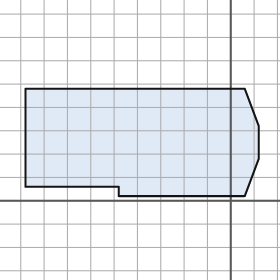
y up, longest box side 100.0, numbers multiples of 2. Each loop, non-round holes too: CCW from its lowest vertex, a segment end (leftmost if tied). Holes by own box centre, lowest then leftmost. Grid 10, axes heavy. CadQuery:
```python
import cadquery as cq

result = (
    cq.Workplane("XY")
    .moveTo(-48.0, 2.0)
    .lineTo(6.0, 2.0)
    .lineTo(12.0, 18.0)
    .lineTo(12.0, 32.0)
    .lineTo(6.0, 48.0)
    .lineTo(-88.0, 48.0)
    .lineTo(-88.0, 6.0)
    .lineTo(-48.0, 6.0)
    .close()
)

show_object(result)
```